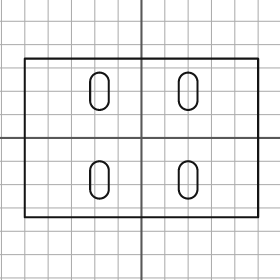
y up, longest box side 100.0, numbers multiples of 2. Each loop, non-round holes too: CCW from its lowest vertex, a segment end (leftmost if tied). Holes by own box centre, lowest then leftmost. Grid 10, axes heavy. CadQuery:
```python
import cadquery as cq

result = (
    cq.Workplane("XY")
    .moveTo(-50.0, -34.0)
    .lineTo(50.0, -34.0)
    .lineTo(50.0, 34.0)
    .lineTo(-50.0, 34.0)
    .close()
    .moveTo(-22.0, -22.0)
    .threePointArc((-18.0, -26.0), (-14.0, -22.0))
    .lineTo(-14.0, -14.0)
    .threePointArc((-18.0, -10.0), (-22.0, -14.0))
    .close()
    .moveTo(16.0, -22.0)
    .threePointArc((20.0, -26.0), (24.0, -22.0))
    .lineTo(24.0, -14.0)
    .threePointArc((20.0, -10.0), (16.0, -14.0))
    .close()
    .moveTo(-22.0, 16.0)
    .threePointArc((-18.0, 12.0), (-14.0, 16.0))
    .lineTo(-14.0, 24.0)
    .threePointArc((-18.0, 28.0), (-22.0, 24.0))
    .close()
    .moveTo(16.0, 16.0)
    .threePointArc((20.0, 12.0), (24.0, 16.0))
    .lineTo(24.0, 24.0)
    .threePointArc((20.0, 28.0), (16.0, 24.0))
    .close()
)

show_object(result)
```